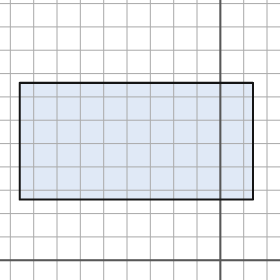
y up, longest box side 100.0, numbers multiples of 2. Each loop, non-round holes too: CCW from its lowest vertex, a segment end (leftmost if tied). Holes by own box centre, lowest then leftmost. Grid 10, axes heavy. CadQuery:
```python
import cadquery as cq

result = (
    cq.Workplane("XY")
    .moveTo(-86.0, 26.0)
    .lineTo(14.0, 26.0)
    .lineTo(14.0, 76.0)
    .lineTo(-86.0, 76.0)
    .close()
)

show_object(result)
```